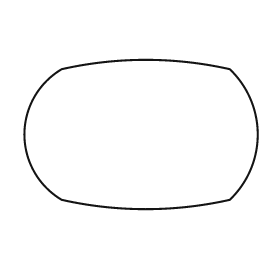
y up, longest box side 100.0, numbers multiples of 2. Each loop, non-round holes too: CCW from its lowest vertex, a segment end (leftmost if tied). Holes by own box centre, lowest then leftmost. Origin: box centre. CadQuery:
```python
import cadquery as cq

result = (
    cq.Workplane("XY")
    .moveTo(-34.0, -28.0)
    .threePointArc((2.0, -32.0), (38.0, -28.0))
    .threePointArc((50.0, 0.0), (38.0, 28.0))
    .threePointArc((2.0, 32.0), (-34.0, 28.0))
    .threePointArc((-50.0, 0.0), (-34.0, -28.0))
    .close()
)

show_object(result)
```